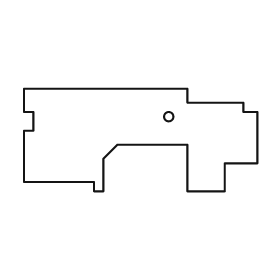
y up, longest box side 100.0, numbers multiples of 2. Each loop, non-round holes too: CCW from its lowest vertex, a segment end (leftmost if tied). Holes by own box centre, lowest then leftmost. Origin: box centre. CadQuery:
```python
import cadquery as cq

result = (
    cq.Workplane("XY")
    .moveTo(-20.0, -22.0)
    .lineTo(-16.0, -22.0)
    .lineTo(-16.0, -8.0)
    .lineTo(-10.0, -2.0)
    .lineTo(20.0, -2.0)
    .lineTo(20.0, -22.0)
    .lineTo(36.0, -22.0)
    .lineTo(36.0, -10.0)
    .lineTo(50.0, -10.0)
    .lineTo(50.0, 12.0)
    .lineTo(44.0, 12.0)
    .lineTo(44.0, 16.0)
    .lineTo(20.0, 16.0)
    .lineTo(20.0, 22.0)
    .lineTo(-50.0, 22.0)
    .lineTo(-50.0, 12.0)
    .lineTo(-46.0, 12.0)
    .lineTo(-46.0, 4.0)
    .lineTo(-50.0, 4.0)
    .lineTo(-50.0, -18.0)
    .lineTo(-20.0, -18.0)
    .close()
    .moveTo(12.0, 10.0)
    .circle(2.0)
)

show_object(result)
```